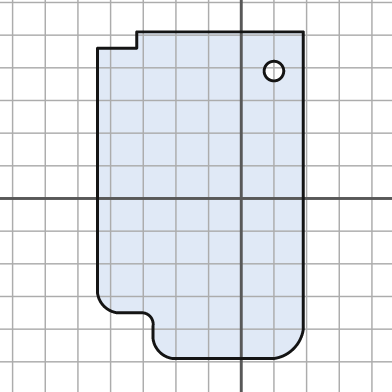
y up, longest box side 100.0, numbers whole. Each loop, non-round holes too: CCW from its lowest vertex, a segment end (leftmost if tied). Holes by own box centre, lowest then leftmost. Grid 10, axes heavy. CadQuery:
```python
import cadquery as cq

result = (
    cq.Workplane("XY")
    .moveTo(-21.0, -49.0)
    .lineTo(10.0, -49.0)
    .threePointArc((16.0, -46.0), (19.0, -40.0))
    .lineTo(19.0, 51.0)
    .lineTo(-32.0, 51.0)
    .lineTo(-32.0, 46.0)
    .lineTo(-44.0, 46.0)
    .lineTo(-44.0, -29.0)
    .threePointArc((-42.0, -33.0), (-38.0, -35.0))
    .lineTo(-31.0, -35.0)
    .threePointArc((-28.0, -36.0), (-27.0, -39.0))
    .lineTo(-27.0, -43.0)
    .threePointArc((-25.0, -47.0), (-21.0, -49.0))
    .close()
    .moveTo(10.0, 39.0)
    .circle(3.0)
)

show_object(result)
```